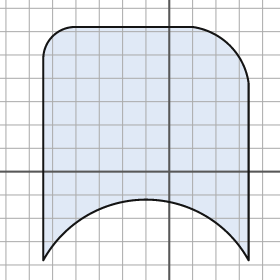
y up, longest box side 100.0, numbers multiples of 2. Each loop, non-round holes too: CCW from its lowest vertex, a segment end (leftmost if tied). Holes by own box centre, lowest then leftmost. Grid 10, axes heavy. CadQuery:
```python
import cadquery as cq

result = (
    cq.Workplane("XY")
    .moveTo(-54.0, -38.0)
    .threePointArc((-10.0, -12.0), (34.0, -38.0))
    .lineTo(34.0, 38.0)
    .threePointArc((26.0, 54.0), (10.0, 62.0))
    .lineTo(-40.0, 62.0)
    .threePointArc((-50.0, 58.0), (-54.0, 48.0))
    .close()
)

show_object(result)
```